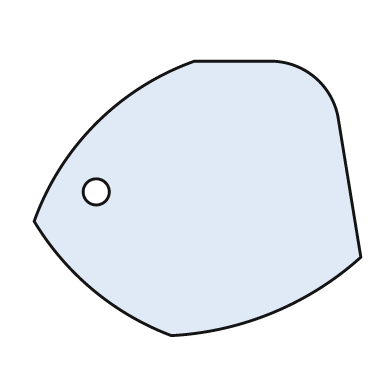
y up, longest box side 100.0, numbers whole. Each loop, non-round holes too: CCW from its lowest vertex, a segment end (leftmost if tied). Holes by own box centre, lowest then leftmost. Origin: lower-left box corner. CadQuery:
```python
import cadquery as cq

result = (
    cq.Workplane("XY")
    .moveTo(42.0, 0.0)
    .threePointArc((73.0, 7.0), (100.0, 24.0))
    .lineTo(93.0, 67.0)
    .threePointArc((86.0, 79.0), (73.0, 84.0))
    .lineTo(49.0, 84.0)
    .threePointArc((19.0, 65.0), (0.0, 35.0))
    .threePointArc((18.0, 14.0), (42.0, 0.0))
    .close()
    .moveTo(19.0, 44.0)
    .circle(4.0)
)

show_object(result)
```